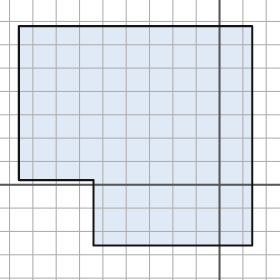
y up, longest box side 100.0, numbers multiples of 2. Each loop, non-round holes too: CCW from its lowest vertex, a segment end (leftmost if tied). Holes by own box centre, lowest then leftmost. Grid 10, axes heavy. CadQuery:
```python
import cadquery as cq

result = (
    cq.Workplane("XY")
    .moveTo(-54.0, -26.0)
    .lineTo(14.0, -26.0)
    .lineTo(14.0, 68.0)
    .lineTo(-86.0, 68.0)
    .lineTo(-86.0, 2.0)
    .lineTo(-54.0, 2.0)
    .close()
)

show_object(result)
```